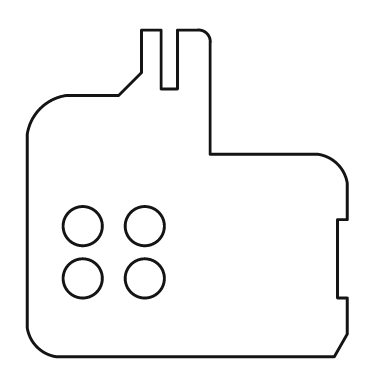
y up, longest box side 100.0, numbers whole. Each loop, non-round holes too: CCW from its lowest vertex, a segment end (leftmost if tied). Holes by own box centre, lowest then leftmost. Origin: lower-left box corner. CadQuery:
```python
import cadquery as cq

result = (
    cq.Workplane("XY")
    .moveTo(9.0, 0.0)
    .lineTo(94.0, 0.0)
    .lineTo(98.0, 7.0)
    .lineTo(98.0, 18.0)
    .lineTo(95.0, 18.0)
    .lineTo(95.0, 42.0)
    .lineTo(98.0, 42.0)
    .lineTo(98.0, 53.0)
    .threePointArc((95.0, 59.0), (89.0, 62.0))
    .lineTo(56.0, 62.0)
    .lineTo(56.0, 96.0)
    .threePointArc((55.0, 99.0), (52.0, 100.0))
    .lineTo(46.0, 100.0)
    .lineTo(46.0, 82.0)
    .lineTo(41.0, 82.0)
    .lineTo(41.0, 100.0)
    .lineTo(35.0, 100.0)
    .lineTo(35.0, 87.0)
    .lineTo(28.0, 80.0)
    .lineTo(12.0, 80.0)
    .threePointArc((4.0, 76.0), (0.0, 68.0))
    .lineTo(0.0, 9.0)
    .threePointArc((3.0, 3.0), (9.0, 0.0))
    .close()
    .moveTo(17.0, 24.0)
    .circle(6.0)
    .moveTo(36.0, 24.0)
    .circle(6.0)
    .moveTo(17.0, 40.0)
    .circle(6.0)
    .moveTo(36.0, 40.0)
    .circle(6.0)
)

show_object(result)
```